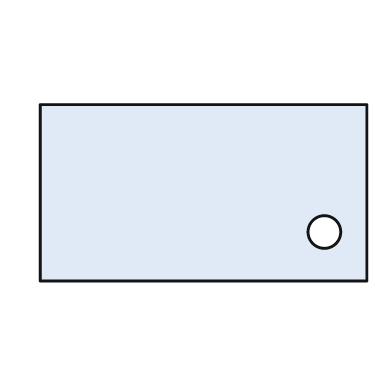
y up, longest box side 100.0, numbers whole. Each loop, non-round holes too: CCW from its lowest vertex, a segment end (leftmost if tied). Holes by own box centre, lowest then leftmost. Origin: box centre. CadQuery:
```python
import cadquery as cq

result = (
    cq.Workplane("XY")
    .moveTo(-50.0, -27.0)
    .lineTo(50.0, -27.0)
    .lineTo(50.0, 27.0)
    .lineTo(-50.0, 27.0)
    .close()
    .moveTo(37.0, -12.0)
    .circle(5.0)
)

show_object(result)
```